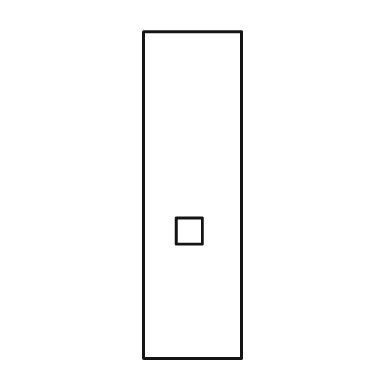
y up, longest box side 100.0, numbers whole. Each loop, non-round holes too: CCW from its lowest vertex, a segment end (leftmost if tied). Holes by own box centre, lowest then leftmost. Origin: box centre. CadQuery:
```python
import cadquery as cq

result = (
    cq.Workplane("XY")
    .moveTo(-15.0, -50.0)
    .lineTo(15.0, -50.0)
    .lineTo(15.0, 50.0)
    .lineTo(-15.0, 50.0)
    .close()
    .moveTo(-5.0, -15.0)
    .lineTo(3.0, -15.0)
    .lineTo(3.0, -7.0)
    .lineTo(-5.0, -7.0)
    .close()
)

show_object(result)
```